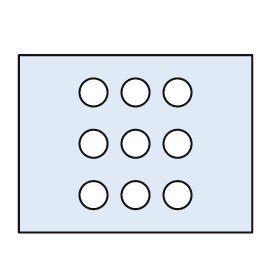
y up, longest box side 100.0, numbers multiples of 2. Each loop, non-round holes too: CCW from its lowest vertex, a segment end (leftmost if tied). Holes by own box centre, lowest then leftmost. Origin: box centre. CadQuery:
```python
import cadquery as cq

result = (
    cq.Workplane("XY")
    .moveTo(-50.0, -38.0)
    .lineTo(50.0, -38.0)
    .lineTo(50.0, 38.0)
    .lineTo(-50.0, 38.0)
    .close()
    .moveTo(-18.0, -22.0)
    .circle(6.0)
    .moveTo(0.0, -22.0)
    .circle(6.0)
    .moveTo(18.0, -22.0)
    .circle(6.0)
    .moveTo(-18.0, 0.0)
    .circle(6.0)
    .moveTo(0.0, 0.0)
    .circle(6.0)
    .moveTo(18.0, 0.0)
    .circle(6.0)
    .moveTo(-18.0, 22.0)
    .circle(6.0)
    .moveTo(0.0, 22.0)
    .circle(6.0)
    .moveTo(18.0, 22.0)
    .circle(6.0)
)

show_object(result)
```